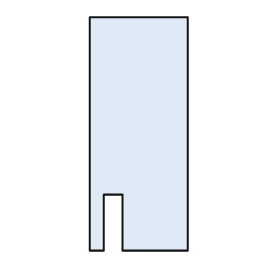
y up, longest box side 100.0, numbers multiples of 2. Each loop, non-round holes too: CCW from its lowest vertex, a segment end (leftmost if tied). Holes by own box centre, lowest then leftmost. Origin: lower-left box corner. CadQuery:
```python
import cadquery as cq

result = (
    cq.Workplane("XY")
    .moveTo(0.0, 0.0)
    .lineTo(6.0, 0.0)
    .lineTo(6.0, 24.0)
    .lineTo(14.0, 24.0)
    .lineTo(14.0, 0.0)
    .lineTo(42.0, 0.0)
    .lineTo(42.0, 100.0)
    .lineTo(0.0, 100.0)
    .close()
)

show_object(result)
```